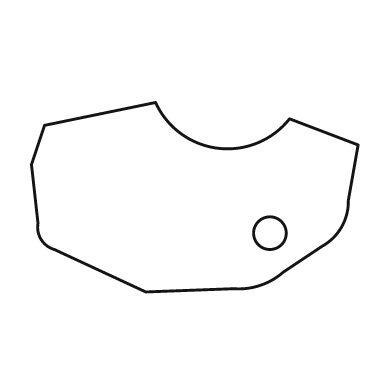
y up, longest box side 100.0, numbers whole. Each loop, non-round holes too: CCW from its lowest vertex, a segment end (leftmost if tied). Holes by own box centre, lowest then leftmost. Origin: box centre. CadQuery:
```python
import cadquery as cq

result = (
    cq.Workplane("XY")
    .moveTo(-15.0, -29.0)
    .lineTo(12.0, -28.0)
    .threePointArc((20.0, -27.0), (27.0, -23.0))
    .lineTo(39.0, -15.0)
    .threePointArc((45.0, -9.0), (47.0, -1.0))
    .lineTo(50.0, 16.0)
    .lineTo(29.0, 24.0)
    .threePointArc((7.0, 15.0), (-12.0, 29.0))
    .lineTo(-46.0, 22.0)
    .lineTo(-50.0, 10.0)
    .lineTo(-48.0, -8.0)
    .threePointArc((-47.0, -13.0), (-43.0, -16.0))
    .close()
    .moveTo(23.0, -11.0)
    .circle(5.0)
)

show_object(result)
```